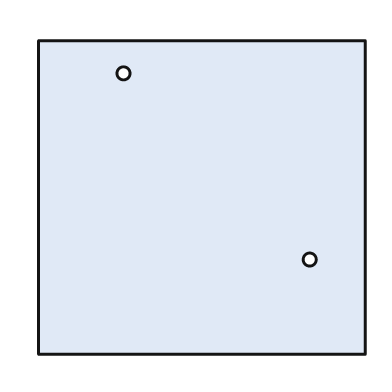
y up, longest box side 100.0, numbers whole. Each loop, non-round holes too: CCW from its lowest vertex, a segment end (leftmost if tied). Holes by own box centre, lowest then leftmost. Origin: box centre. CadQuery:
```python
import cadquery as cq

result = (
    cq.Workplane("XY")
    .moveTo(-50.0, -48.0)
    .lineTo(50.0, -48.0)
    .lineTo(50.0, 48.0)
    .lineTo(-50.0, 48.0)
    .close()
    .moveTo(33.0, -19.0)
    .circle(2.0)
    .moveTo(-24.0, 38.0)
    .circle(2.0)
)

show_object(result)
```